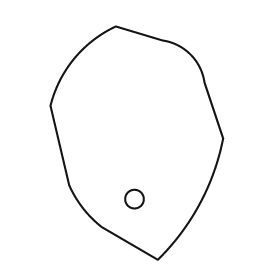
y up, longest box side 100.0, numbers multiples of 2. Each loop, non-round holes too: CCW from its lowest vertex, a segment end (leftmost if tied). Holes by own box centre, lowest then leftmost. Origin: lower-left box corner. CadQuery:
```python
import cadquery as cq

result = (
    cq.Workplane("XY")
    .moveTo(46.0, 0.0)
    .threePointArc((64.0, 24.0), (74.0, 52.0))
    .lineTo(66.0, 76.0)
    .threePointArc((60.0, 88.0), (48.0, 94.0))
    .lineTo(28.0, 100.0)
    .threePointArc((10.0, 86.0), (0.0, 66.0))
    .lineTo(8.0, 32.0)
    .threePointArc((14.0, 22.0), (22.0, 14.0))
    .close()
    .moveTo(36.0, 26.0)
    .circle(4.0)
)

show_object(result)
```